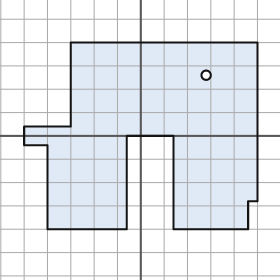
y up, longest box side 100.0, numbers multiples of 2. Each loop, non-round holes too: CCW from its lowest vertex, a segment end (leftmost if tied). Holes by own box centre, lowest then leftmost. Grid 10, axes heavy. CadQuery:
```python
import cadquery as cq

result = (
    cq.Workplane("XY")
    .moveTo(-40.0, -40.0)
    .lineTo(-6.0, -40.0)
    .lineTo(-6.0, 0.0)
    .lineTo(14.0, 0.0)
    .lineTo(14.0, -40.0)
    .lineTo(46.0, -40.0)
    .lineTo(46.0, -28.0)
    .lineTo(50.0, -28.0)
    .lineTo(50.0, 40.0)
    .lineTo(-30.0, 40.0)
    .lineTo(-30.0, 4.0)
    .lineTo(-50.0, 4.0)
    .lineTo(-50.0, -4.0)
    .lineTo(-40.0, -4.0)
    .close()
    .moveTo(28.0, 26.0)
    .circle(2.0)
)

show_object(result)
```